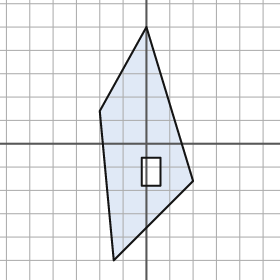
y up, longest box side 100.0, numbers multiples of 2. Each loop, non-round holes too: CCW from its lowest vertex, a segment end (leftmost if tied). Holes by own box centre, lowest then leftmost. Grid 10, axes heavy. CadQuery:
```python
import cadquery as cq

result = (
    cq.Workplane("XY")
    .moveTo(-14.0, -50.0)
    .lineTo(20.0, -16.0)
    .lineTo(0.0, 50.0)
    .lineTo(-20.0, 14.0)
    .close()
    .moveTo(-2.0, -18.0)
    .lineTo(6.0, -18.0)
    .lineTo(6.0, -6.0)
    .lineTo(-2.0, -6.0)
    .close()
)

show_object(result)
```